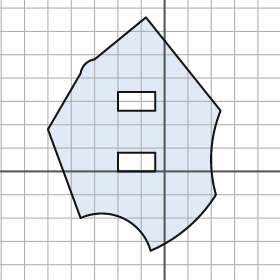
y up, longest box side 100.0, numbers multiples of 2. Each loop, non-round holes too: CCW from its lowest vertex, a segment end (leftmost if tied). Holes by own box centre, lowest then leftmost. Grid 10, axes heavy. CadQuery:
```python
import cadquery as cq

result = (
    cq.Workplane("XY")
    .moveTo(-6.0, -34.0)
    .threePointArc((10.0, -24.0), (22.0, -10.0))
    .threePointArc((20.0, 8.0), (24.0, 26.0))
    .lineTo(-8.0, 66.0)
    .lineTo(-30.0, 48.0)
    .threePointArc((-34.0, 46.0), (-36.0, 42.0))
    .lineTo(-50.0, 18.0)
    .lineTo(-36.0, -20.0)
    .threePointArc((-18.0, -20.0), (-6.0, -34.0))
    .close()
    .moveTo(-20.0, 0.0)
    .lineTo(-4.0, 0.0)
    .lineTo(-4.0, 8.0)
    .lineTo(-20.0, 8.0)
    .close()
    .moveTo(-20.0, 26.0)
    .lineTo(-4.0, 26.0)
    .lineTo(-4.0, 34.0)
    .lineTo(-20.0, 34.0)
    .close()
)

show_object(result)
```